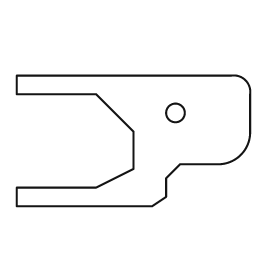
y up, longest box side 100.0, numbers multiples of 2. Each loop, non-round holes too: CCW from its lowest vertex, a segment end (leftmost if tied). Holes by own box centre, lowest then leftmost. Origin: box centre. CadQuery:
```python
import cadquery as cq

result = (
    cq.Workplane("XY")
    .moveTo(-50.0, -28.0)
    .lineTo(8.0, -28.0)
    .lineTo(14.0, -24.0)
    .lineTo(14.0, -16.0)
    .lineTo(20.0, -10.0)
    .lineTo(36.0, -10.0)
    .threePointArc((46.0, -6.0), (50.0, 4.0))
    .lineTo(50.0, 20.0)
    .threePointArc((48.0, 26.0), (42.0, 28.0))
    .lineTo(-50.0, 28.0)
    .lineTo(-50.0, 20.0)
    .lineTo(-16.0, 20.0)
    .lineTo(0.0, 4.0)
    .lineTo(0.0, -12.0)
    .lineTo(-16.0, -20.0)
    .lineTo(-50.0, -20.0)
    .close()
    .moveTo(18.0, 12.0)
    .circle(4.0)
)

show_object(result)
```